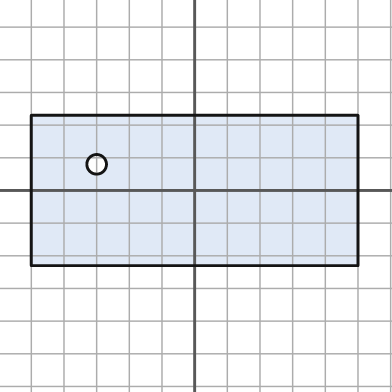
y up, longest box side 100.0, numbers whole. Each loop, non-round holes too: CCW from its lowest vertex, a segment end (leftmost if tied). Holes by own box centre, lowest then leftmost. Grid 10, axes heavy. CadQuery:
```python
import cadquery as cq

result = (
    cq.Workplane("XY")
    .moveTo(-50.0, -23.0)
    .lineTo(50.0, -23.0)
    .lineTo(50.0, 23.0)
    .lineTo(-50.0, 23.0)
    .close()
    .moveTo(-30.0, 8.0)
    .circle(3.0)
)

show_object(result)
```